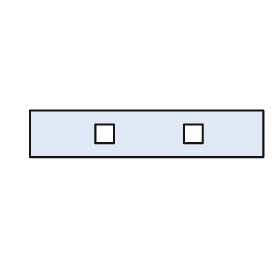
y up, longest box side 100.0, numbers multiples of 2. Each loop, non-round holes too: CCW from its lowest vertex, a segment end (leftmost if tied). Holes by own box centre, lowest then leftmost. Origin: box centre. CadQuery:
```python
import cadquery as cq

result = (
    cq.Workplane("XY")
    .moveTo(-50.0, -10.0)
    .lineTo(50.0, -10.0)
    .lineTo(50.0, 10.0)
    .lineTo(-50.0, 10.0)
    .close()
    .moveTo(-22.0, -4.0)
    .lineTo(-14.0, -4.0)
    .lineTo(-14.0, 4.0)
    .lineTo(-22.0, 4.0)
    .close()
    .moveTo(16.0, -4.0)
    .lineTo(24.0, -4.0)
    .lineTo(24.0, 4.0)
    .lineTo(16.0, 4.0)
    .close()
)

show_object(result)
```